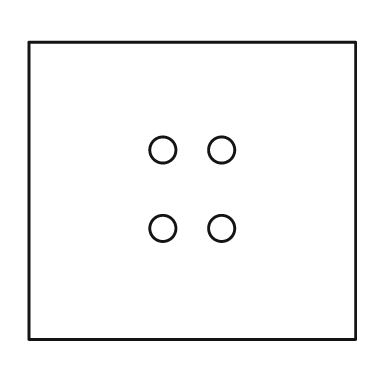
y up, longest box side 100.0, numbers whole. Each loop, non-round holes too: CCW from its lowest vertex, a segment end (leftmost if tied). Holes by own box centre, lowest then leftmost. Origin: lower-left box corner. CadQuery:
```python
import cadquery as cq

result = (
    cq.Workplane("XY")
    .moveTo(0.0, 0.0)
    .lineTo(100.0, 0.0)
    .lineTo(100.0, 91.0)
    .lineTo(0.0, 91.0)
    .close()
    .moveTo(41.0, 34.0)
    .circle(4.0)
    .moveTo(59.0, 34.0)
    .circle(4.0)
    .moveTo(41.0, 58.0)
    .circle(4.0)
    .moveTo(59.0, 58.0)
    .circle(4.0)
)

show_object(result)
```